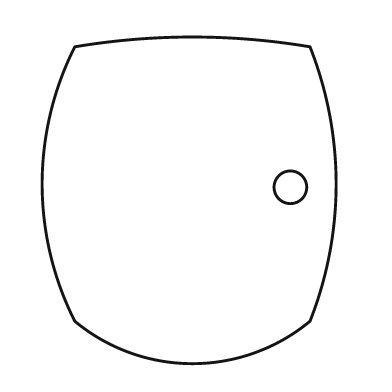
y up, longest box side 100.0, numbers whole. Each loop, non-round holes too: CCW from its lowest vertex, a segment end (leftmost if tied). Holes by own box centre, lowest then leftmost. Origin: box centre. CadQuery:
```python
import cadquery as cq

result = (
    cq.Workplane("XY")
    .moveTo(-35.0, -37.0)
    .threePointArc((1.0, -50.0), (37.0, -37.0))
    .threePointArc((45.0, 5.0), (37.0, 47.0))
    .threePointArc((1.0, 50.0), (-35.0, 47.0))
    .threePointArc((-45.0, 5.0), (-35.0, -37.0))
    .close()
    .moveTo(31.0, 4.0)
    .circle(5.0)
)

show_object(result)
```